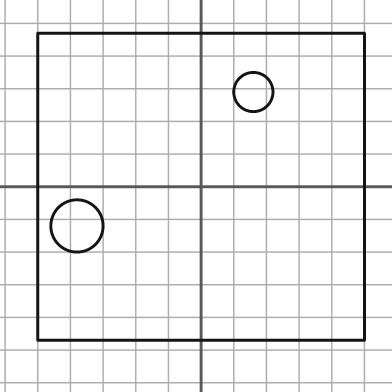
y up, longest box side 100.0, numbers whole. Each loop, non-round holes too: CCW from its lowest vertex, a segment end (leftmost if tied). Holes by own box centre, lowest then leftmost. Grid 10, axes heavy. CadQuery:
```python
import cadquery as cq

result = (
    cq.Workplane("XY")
    .moveTo(-50.0, -47.0)
    .lineTo(50.0, -47.0)
    .lineTo(50.0, 47.0)
    .lineTo(-50.0, 47.0)
    .close()
    .moveTo(-38.0, -12.0)
    .circle(8.0)
    .moveTo(16.0, 29.0)
    .circle(6.0)
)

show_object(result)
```